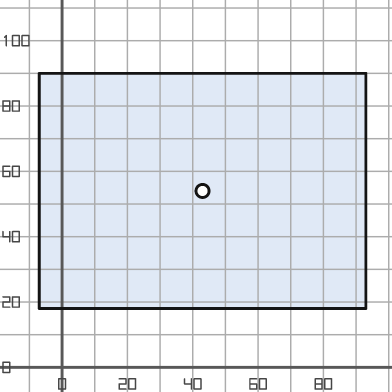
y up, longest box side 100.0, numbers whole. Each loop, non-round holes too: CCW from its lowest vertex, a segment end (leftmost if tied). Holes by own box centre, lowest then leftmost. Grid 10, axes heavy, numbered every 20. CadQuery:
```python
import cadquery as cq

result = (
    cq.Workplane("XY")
    .moveTo(-7.0, 18.0)
    .lineTo(93.0, 18.0)
    .lineTo(93.0, 90.0)
    .lineTo(-7.0, 90.0)
    .close()
    .moveTo(43.0, 54.0)
    .circle(2.0)
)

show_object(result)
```